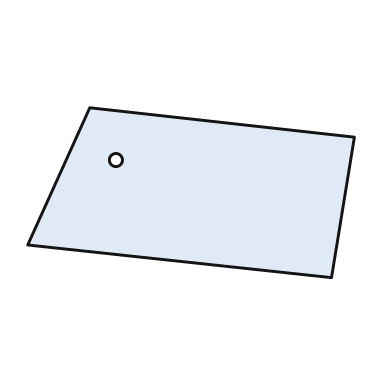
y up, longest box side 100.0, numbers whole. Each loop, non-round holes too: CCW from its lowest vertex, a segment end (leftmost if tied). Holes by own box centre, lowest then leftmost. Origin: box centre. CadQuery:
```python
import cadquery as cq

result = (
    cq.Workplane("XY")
    .moveTo(43.0, -26.0)
    .lineTo(50.0, 17.0)
    .lineTo(-31.0, 26.0)
    .lineTo(-50.0, -16.0)
    .close()
    .moveTo(-23.0, 10.0)
    .circle(2.0)
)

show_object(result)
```